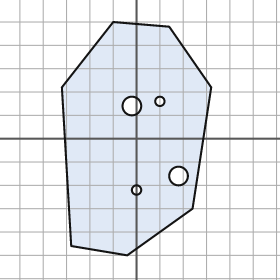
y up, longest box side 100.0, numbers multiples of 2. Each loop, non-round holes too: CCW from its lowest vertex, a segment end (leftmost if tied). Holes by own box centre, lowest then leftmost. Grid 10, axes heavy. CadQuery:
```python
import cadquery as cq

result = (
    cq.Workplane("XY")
    .moveTo(-4.0, -50.0)
    .lineTo(24.0, -30.0)
    .lineTo(32.0, 22.0)
    .lineTo(14.0, 48.0)
    .lineTo(-10.0, 50.0)
    .lineTo(-32.0, 22.0)
    .lineTo(-28.0, -46.0)
    .close()
    .moveTo(0.0, -22.0)
    .circle(2.0)
    .moveTo(18.0, -16.0)
    .circle(4.0)
    .moveTo(-2.0, 14.0)
    .circle(4.0)
    .moveTo(10.0, 16.0)
    .circle(2.0)
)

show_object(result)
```